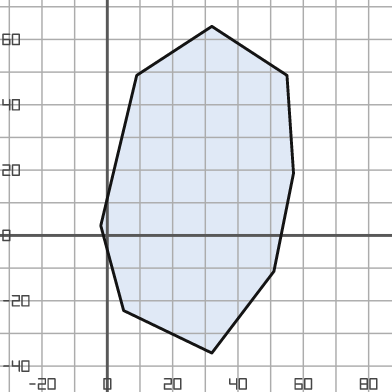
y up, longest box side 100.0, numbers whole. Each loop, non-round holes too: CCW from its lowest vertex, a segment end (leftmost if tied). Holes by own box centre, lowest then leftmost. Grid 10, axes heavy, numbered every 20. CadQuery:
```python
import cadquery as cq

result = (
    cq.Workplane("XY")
    .moveTo(32.0, -36.0)
    .lineTo(51.0, -11.0)
    .lineTo(57.0, 19.0)
    .lineTo(55.0, 49.0)
    .lineTo(32.0, 64.0)
    .lineTo(9.0, 49.0)
    .lineTo(-2.0, 3.0)
    .lineTo(5.0, -23.0)
    .close()
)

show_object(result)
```